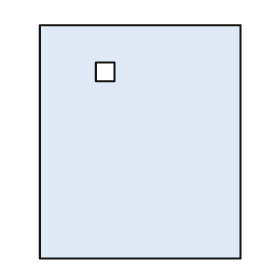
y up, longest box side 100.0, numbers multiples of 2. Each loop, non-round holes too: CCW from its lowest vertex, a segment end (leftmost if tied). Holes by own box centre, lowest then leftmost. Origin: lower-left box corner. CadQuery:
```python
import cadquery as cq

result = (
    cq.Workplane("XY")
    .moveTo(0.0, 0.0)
    .lineTo(86.0, 0.0)
    .lineTo(86.0, 100.0)
    .lineTo(0.0, 100.0)
    .close()
    .moveTo(24.0, 76.0)
    .lineTo(32.0, 76.0)
    .lineTo(32.0, 84.0)
    .lineTo(24.0, 84.0)
    .close()
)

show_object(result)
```